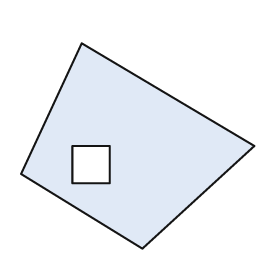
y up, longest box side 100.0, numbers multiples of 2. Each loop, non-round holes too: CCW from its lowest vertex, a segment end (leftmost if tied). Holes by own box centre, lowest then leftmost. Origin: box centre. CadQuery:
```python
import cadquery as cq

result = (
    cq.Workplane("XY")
    .moveTo(2.0, -44.0)
    .lineTo(50.0, 0.0)
    .lineTo(-24.0, 44.0)
    .lineTo(-50.0, -12.0)
    .close()
    .moveTo(-28.0, -16.0)
    .lineTo(-12.0, -16.0)
    .lineTo(-12.0, 0.0)
    .lineTo(-28.0, 0.0)
    .close()
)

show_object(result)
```